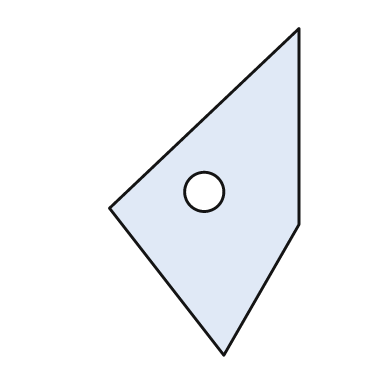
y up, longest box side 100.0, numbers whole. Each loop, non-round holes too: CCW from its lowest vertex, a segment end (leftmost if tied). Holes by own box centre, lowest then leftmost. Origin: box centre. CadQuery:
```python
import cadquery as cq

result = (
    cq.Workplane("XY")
    .moveTo(6.0, -50.0)
    .lineTo(29.0, -10.0)
    .lineTo(29.0, 50.0)
    .lineTo(-29.0, -5.0)
    .close()
    .moveTo(0.0, 0.0)
    .circle(6.0)
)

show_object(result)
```